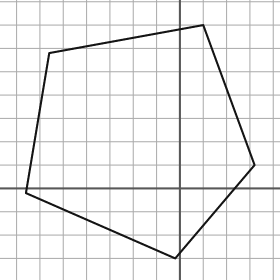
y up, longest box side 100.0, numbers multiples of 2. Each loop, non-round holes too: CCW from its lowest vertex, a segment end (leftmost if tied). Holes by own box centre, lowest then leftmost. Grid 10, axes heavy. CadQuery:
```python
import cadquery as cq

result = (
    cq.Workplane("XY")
    .moveTo(-2.0, -30.0)
    .lineTo(32.0, 10.0)
    .lineTo(10.0, 70.0)
    .lineTo(-56.0, 58.0)
    .lineTo(-66.0, -2.0)
    .close()
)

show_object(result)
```